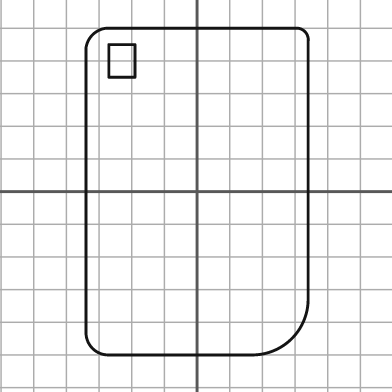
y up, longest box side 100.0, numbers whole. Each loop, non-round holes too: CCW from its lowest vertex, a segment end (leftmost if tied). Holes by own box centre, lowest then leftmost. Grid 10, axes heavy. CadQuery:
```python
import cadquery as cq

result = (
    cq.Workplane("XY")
    .moveTo(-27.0, -50.0)
    .lineTo(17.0, -50.0)
    .threePointArc((29.0, -45.0), (34.0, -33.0))
    .lineTo(34.0, 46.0)
    .threePointArc((33.0, 49.0), (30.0, 50.0))
    .lineTo(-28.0, 50.0)
    .threePointArc((-32.0, 48.0), (-34.0, 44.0))
    .lineTo(-34.0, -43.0)
    .threePointArc((-32.0, -48.0), (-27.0, -50.0))
    .close()
    .moveTo(-27.0, 35.0)
    .lineTo(-19.0, 35.0)
    .lineTo(-19.0, 45.0)
    .lineTo(-27.0, 45.0)
    .close()
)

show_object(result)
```